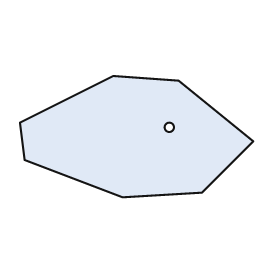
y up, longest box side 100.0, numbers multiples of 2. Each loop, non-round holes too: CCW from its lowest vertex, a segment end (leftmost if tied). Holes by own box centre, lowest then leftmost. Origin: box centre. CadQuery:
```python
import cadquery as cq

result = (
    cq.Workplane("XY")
    .moveTo(-6.0, -26.0)
    .lineTo(28.0, -24.0)
    .lineTo(50.0, -2.0)
    .lineTo(18.0, 24.0)
    .lineTo(-10.0, 26.0)
    .lineTo(-50.0, 6.0)
    .lineTo(-48.0, -10.0)
    .close()
    .moveTo(14.0, 4.0)
    .circle(2.0)
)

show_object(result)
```